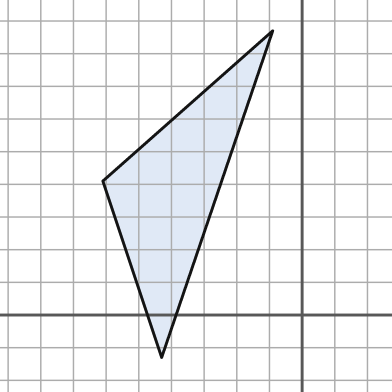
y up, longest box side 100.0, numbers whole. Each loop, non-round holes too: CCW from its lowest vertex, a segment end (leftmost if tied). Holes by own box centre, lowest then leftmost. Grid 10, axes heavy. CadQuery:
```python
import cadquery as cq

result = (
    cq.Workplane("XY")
    .moveTo(-43.0, -13.0)
    .lineTo(-9.0, 87.0)
    .lineTo(-61.0, 41.0)
    .close()
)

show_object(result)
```